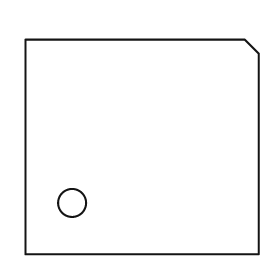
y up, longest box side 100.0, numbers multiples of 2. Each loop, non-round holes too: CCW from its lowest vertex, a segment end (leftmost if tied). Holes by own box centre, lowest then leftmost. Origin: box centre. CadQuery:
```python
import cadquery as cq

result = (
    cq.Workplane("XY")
    .moveTo(-50.0, -46.0)
    .lineTo(50.0, -46.0)
    .lineTo(50.0, 40.0)
    .lineTo(44.0, 46.0)
    .lineTo(-50.0, 46.0)
    .close()
    .moveTo(-30.0, -24.0)
    .circle(6.0)
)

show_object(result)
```